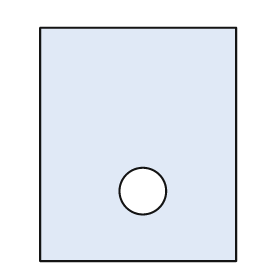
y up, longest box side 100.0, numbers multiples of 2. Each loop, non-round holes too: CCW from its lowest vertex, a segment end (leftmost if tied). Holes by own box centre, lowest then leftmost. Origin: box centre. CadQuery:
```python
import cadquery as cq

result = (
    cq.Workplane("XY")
    .moveTo(-42.0, -50.0)
    .lineTo(42.0, -50.0)
    .lineTo(42.0, 50.0)
    .lineTo(-42.0, 50.0)
    .close()
    .moveTo(2.0, -20.0)
    .circle(10.0)
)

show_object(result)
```